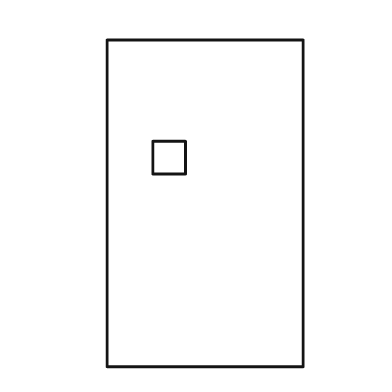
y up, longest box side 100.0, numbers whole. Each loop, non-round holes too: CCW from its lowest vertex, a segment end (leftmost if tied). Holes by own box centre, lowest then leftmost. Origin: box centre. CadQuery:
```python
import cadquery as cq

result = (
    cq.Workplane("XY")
    .moveTo(-30.0, -50.0)
    .lineTo(30.0, -50.0)
    .lineTo(30.0, 50.0)
    .lineTo(-30.0, 50.0)
    .close()
    .moveTo(-16.0, 9.0)
    .lineTo(-6.0, 9.0)
    .lineTo(-6.0, 19.0)
    .lineTo(-16.0, 19.0)
    .close()
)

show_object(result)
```